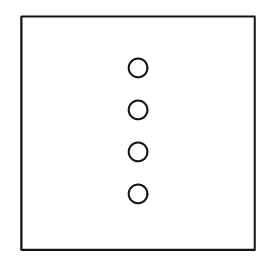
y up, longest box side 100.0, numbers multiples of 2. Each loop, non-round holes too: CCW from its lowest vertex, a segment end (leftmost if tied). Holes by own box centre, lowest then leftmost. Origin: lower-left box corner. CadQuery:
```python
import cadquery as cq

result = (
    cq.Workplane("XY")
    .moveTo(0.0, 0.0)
    .lineTo(100.0, 0.0)
    .lineTo(100.0, 100.0)
    .lineTo(0.0, 100.0)
    .close()
    .moveTo(50.0, 24.0)
    .circle(4.0)
    .moveTo(50.0, 42.0)
    .circle(4.0)
    .moveTo(50.0, 60.0)
    .circle(4.0)
    .moveTo(50.0, 78.0)
    .circle(4.0)
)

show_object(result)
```